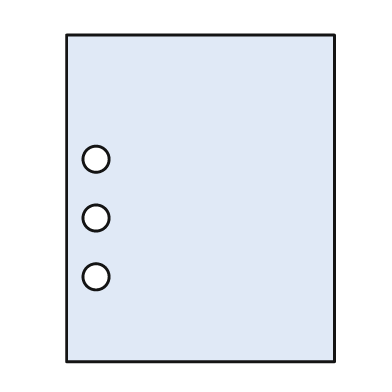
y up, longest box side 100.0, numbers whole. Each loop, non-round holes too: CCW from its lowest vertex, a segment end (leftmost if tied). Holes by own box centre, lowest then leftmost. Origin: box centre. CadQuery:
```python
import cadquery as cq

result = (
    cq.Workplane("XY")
    .moveTo(-41.0, -50.0)
    .lineTo(41.0, -50.0)
    .lineTo(41.0, 50.0)
    .lineTo(-41.0, 50.0)
    .close()
    .moveTo(-32.0, -24.0)
    .circle(4.0)
    .moveTo(-32.0, -6.0)
    .circle(4.0)
    .moveTo(-32.0, 12.0)
    .circle(4.0)
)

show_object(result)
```